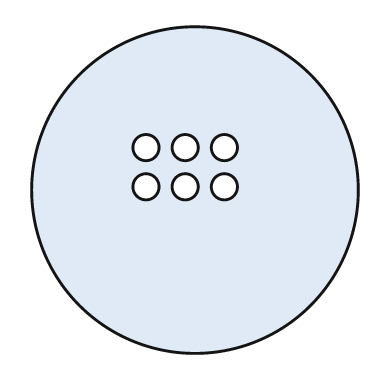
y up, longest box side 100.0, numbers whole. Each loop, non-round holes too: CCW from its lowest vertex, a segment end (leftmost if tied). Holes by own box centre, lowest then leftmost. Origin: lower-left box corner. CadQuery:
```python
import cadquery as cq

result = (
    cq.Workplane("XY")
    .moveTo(50.0, 50.0)
    .circle(50.0)
    .moveTo(35.0, 51.0)
    .circle(4.0)
    .moveTo(47.0, 51.0)
    .circle(4.0)
    .moveTo(59.0, 51.0)
    .circle(4.0)
    .moveTo(35.0, 63.0)
    .circle(4.0)
    .moveTo(47.0, 63.0)
    .circle(4.0)
    .moveTo(59.0, 63.0)
    .circle(4.0)
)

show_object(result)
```